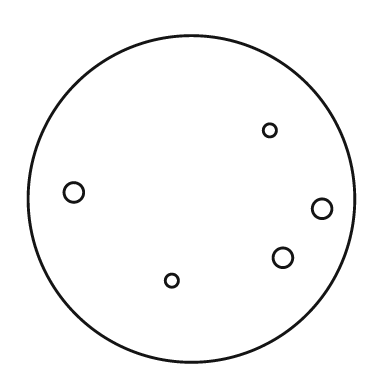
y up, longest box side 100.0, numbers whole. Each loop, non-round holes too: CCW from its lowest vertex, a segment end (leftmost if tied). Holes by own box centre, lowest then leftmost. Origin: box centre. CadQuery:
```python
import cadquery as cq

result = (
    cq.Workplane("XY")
    .moveTo(0.0, 0.0)
    .circle(50.0)
    .moveTo(-6.0, -25.0)
    .circle(2.0)
    .moveTo(28.0, -18.0)
    .circle(3.0)
    .moveTo(40.0, -3.0)
    .circle(3.0)
    .moveTo(-36.0, 2.0)
    .circle(3.0)
    .moveTo(24.0, 21.0)
    .circle(2.0)
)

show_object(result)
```